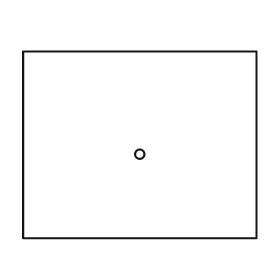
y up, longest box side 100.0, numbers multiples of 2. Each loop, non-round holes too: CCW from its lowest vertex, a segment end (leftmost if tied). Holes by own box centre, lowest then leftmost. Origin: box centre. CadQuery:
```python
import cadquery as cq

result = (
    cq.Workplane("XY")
    .moveTo(-50.0, -40.0)
    .lineTo(50.0, -40.0)
    .lineTo(50.0, 40.0)
    .lineTo(-50.0, 40.0)
    .close()
    .moveTo(0.0, -4.0)
    .circle(2.0)
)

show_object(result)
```